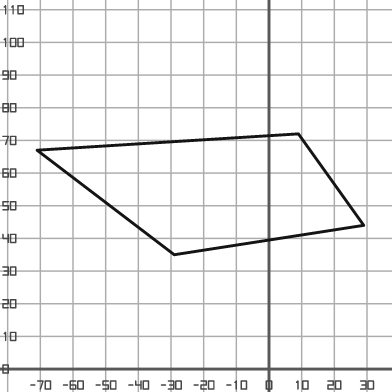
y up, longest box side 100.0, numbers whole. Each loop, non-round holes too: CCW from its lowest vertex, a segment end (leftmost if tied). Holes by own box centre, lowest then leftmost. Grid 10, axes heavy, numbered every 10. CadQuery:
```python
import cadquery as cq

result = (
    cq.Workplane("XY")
    .moveTo(-29.0, 35.0)
    .lineTo(29.0, 44.0)
    .lineTo(9.0, 72.0)
    .lineTo(-71.0, 67.0)
    .close()
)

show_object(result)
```